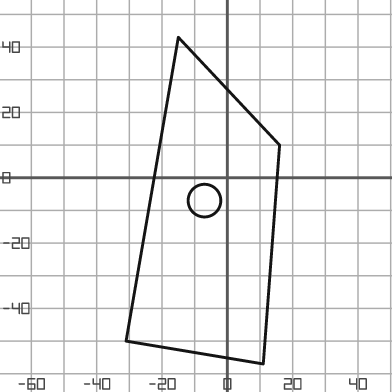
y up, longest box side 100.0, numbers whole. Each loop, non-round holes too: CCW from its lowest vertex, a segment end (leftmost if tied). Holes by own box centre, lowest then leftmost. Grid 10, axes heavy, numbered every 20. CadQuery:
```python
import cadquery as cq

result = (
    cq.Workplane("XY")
    .moveTo(11.0, -57.0)
    .lineTo(16.0, 10.0)
    .lineTo(-15.0, 43.0)
    .lineTo(-31.0, -50.0)
    .close()
    .moveTo(-7.0, -7.0)
    .circle(5.0)
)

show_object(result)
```